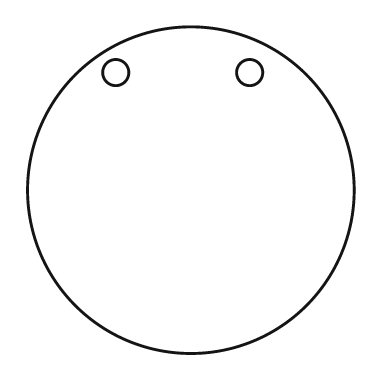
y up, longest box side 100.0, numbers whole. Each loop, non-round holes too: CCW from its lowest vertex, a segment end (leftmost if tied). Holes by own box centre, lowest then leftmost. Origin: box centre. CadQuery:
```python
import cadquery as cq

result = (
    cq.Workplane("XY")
    .moveTo(0.0, 0.0)
    .circle(50.0)
    .moveTo(-23.0, 36.0)
    .circle(4.0)
    .moveTo(18.0, 36.0)
    .circle(4.0)
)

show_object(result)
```